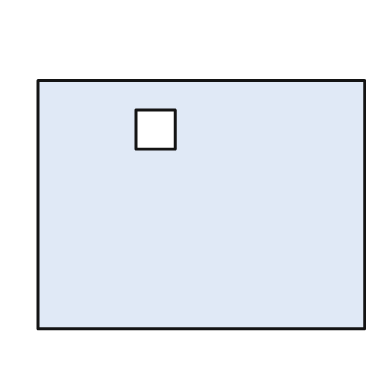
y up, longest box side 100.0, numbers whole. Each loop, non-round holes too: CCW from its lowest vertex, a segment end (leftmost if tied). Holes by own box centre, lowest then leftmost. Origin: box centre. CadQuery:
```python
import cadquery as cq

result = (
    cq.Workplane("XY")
    .moveTo(-50.0, -38.0)
    .lineTo(50.0, -38.0)
    .lineTo(50.0, 38.0)
    .lineTo(-50.0, 38.0)
    .close()
    .moveTo(-20.0, 17.0)
    .lineTo(-8.0, 17.0)
    .lineTo(-8.0, 29.0)
    .lineTo(-20.0, 29.0)
    .close()
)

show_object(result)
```